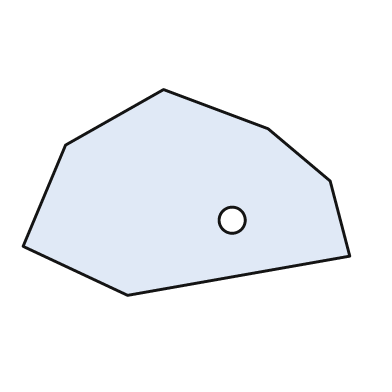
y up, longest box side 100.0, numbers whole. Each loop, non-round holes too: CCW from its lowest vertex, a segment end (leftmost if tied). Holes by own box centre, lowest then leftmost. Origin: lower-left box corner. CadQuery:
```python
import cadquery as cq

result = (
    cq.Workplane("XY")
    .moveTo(32.0, 0.0)
    .lineTo(100.0, 12.0)
    .lineTo(94.0, 35.0)
    .lineTo(75.0, 51.0)
    .lineTo(43.0, 63.0)
    .lineTo(13.0, 46.0)
    .lineTo(0.0, 15.0)
    .close()
    .moveTo(64.0, 23.0)
    .circle(4.0)
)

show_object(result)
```